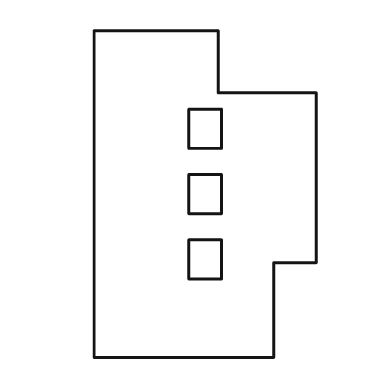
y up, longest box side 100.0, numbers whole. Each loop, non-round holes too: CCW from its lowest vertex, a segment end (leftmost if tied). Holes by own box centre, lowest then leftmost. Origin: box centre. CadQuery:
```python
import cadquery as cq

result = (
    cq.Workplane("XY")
    .moveTo(-34.0, -50.0)
    .lineTo(21.0, -50.0)
    .lineTo(21.0, -21.0)
    .lineTo(34.0, -21.0)
    .lineTo(34.0, 31.0)
    .lineTo(4.0, 31.0)
    .lineTo(4.0, 50.0)
    .lineTo(-34.0, 50.0)
    .close()
    .moveTo(-5.0, -26.0)
    .lineTo(5.0, -26.0)
    .lineTo(5.0, -14.0)
    .lineTo(-5.0, -14.0)
    .close()
    .moveTo(-5.0, -6.0)
    .lineTo(5.0, -6.0)
    .lineTo(5.0, 6.0)
    .lineTo(-5.0, 6.0)
    .close()
    .moveTo(-5.0, 14.0)
    .lineTo(5.0, 14.0)
    .lineTo(5.0, 26.0)
    .lineTo(-5.0, 26.0)
    .close()
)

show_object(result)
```